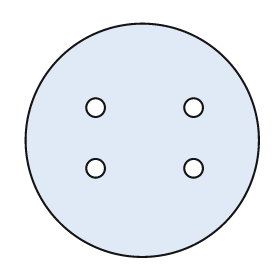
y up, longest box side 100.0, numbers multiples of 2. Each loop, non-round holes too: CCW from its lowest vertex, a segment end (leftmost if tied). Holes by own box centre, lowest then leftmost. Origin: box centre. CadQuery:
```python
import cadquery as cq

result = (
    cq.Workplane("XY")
    .moveTo(0.0, 0.0)
    .circle(50.0)
    .moveTo(-20.0, -12.0)
    .circle(4.0)
    .moveTo(22.0, -12.0)
    .circle(4.0)
    .moveTo(-20.0, 14.0)
    .circle(4.0)
    .moveTo(22.0, 14.0)
    .circle(4.0)
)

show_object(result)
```